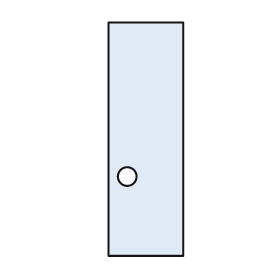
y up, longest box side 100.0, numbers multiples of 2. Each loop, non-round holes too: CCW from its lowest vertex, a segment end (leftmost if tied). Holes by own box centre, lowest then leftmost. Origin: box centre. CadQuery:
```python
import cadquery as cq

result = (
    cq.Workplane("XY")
    .moveTo(-16.0, -50.0)
    .lineTo(16.0, -50.0)
    .lineTo(16.0, 50.0)
    .lineTo(-16.0, 50.0)
    .close()
    .moveTo(-8.0, -16.0)
    .circle(4.0)
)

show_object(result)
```